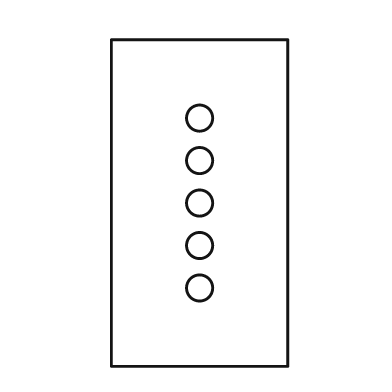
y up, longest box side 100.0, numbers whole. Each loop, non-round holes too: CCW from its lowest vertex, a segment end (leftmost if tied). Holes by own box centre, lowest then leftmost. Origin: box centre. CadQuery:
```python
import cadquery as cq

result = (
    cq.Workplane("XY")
    .moveTo(-27.0, -50.0)
    .lineTo(27.0, -50.0)
    .lineTo(27.0, 50.0)
    .lineTo(-27.0, 50.0)
    .close()
    .moveTo(0.0, -26.0)
    .circle(4.0)
    .moveTo(0.0, -13.0)
    .circle(4.0)
    .moveTo(0.0, 0.0)
    .circle(4.0)
    .moveTo(0.0, 13.0)
    .circle(4.0)
    .moveTo(0.0, 26.0)
    .circle(4.0)
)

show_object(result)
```